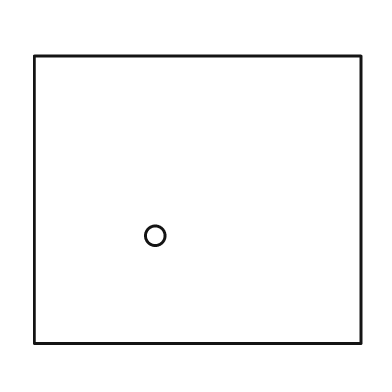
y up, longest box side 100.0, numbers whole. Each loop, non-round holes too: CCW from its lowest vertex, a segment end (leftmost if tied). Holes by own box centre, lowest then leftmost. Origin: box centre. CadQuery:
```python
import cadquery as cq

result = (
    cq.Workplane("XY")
    .moveTo(-50.0, -44.0)
    .lineTo(50.0, -44.0)
    .lineTo(50.0, 44.0)
    .lineTo(-50.0, 44.0)
    .close()
    .moveTo(-13.0, -11.0)
    .circle(3.0)
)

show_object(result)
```